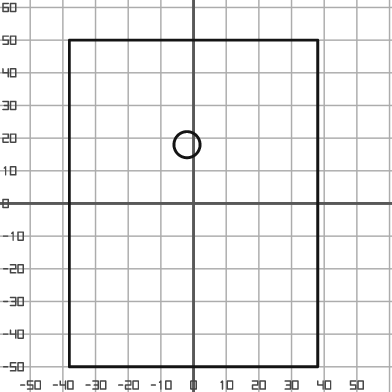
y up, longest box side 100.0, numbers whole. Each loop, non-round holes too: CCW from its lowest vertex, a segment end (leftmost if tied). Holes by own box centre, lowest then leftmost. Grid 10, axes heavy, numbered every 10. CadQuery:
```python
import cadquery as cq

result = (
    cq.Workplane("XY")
    .moveTo(-38.0, -50.0)
    .lineTo(38.0, -50.0)
    .lineTo(38.0, 50.0)
    .lineTo(-38.0, 50.0)
    .close()
    .moveTo(-2.0, 18.0)
    .circle(4.0)
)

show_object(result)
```